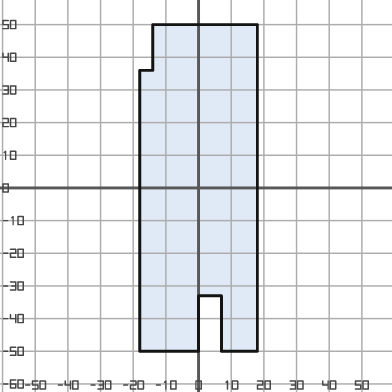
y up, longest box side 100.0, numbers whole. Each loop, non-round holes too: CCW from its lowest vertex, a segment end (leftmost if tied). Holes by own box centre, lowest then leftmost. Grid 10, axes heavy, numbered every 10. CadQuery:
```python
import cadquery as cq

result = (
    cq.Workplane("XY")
    .moveTo(-18.0, -50.0)
    .lineTo(0.0, -50.0)
    .lineTo(0.0, -33.0)
    .lineTo(7.0, -33.0)
    .lineTo(7.0, -50.0)
    .lineTo(18.0, -50.0)
    .lineTo(18.0, 50.0)
    .lineTo(-14.0, 50.0)
    .lineTo(-14.0, 36.0)
    .lineTo(-18.0, 36.0)
    .close()
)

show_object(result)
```